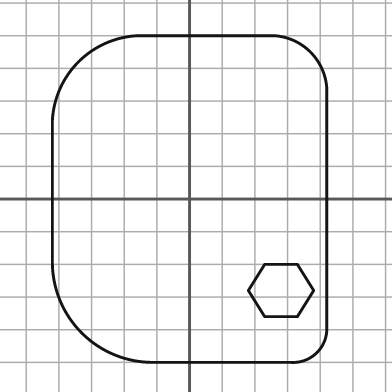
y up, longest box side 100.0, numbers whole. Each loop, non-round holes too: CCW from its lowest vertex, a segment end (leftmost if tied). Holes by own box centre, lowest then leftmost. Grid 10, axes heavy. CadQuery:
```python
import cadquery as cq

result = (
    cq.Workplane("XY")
    .moveTo(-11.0, -50.0)
    .lineTo(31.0, -50.0)
    .threePointArc((39.0, -47.0), (42.0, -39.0))
    .lineTo(42.0, 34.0)
    .threePointArc((37.0, 45.0), (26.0, 50.0))
    .lineTo(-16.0, 50.0)
    .threePointArc((-34.0, 42.0), (-42.0, 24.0))
    .lineTo(-42.0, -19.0)
    .threePointArc((-33.0, -41.0), (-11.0, -50.0))
    .close()
    .moveTo(23.0, -36.0)
    .lineTo(33.0, -36.0)
    .lineTo(38.0, -28.0)
    .lineTo(33.0, -20.0)
    .lineTo(23.0, -20.0)
    .lineTo(18.0, -28.0)
    .close()
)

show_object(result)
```